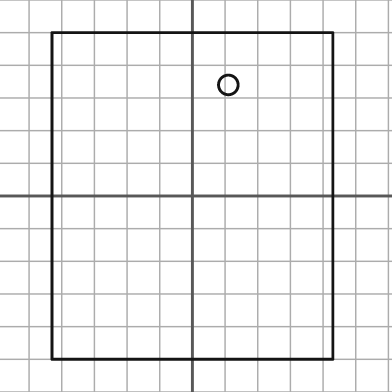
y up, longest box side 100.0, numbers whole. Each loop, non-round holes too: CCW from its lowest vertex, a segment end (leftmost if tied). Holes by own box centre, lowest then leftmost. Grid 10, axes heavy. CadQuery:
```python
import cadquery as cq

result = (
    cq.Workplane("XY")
    .moveTo(-43.0, -50.0)
    .lineTo(43.0, -50.0)
    .lineTo(43.0, 50.0)
    .lineTo(-43.0, 50.0)
    .close()
    .moveTo(11.0, 34.0)
    .circle(3.0)
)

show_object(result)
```